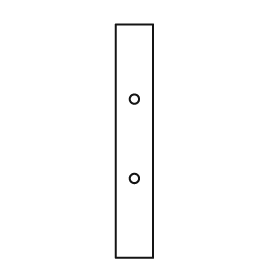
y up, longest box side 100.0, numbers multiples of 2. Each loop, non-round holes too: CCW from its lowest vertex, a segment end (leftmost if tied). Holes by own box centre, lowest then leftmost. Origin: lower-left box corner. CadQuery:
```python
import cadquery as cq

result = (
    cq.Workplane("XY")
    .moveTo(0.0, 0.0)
    .lineTo(16.0, 0.0)
    .lineTo(16.0, 100.0)
    .lineTo(0.0, 100.0)
    .close()
    .moveTo(8.0, 34.0)
    .circle(2.0)
    .moveTo(8.0, 68.0)
    .circle(2.0)
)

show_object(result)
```